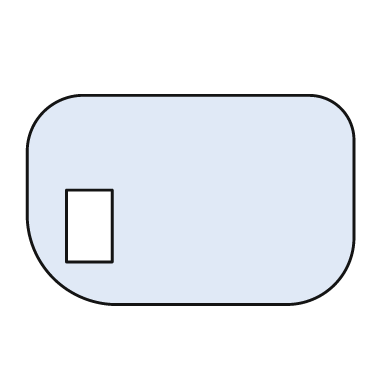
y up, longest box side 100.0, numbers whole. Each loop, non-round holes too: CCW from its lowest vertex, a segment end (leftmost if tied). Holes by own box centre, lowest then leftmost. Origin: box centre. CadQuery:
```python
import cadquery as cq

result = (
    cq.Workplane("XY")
    .moveTo(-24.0, -32.0)
    .lineTo(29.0, -32.0)
    .threePointArc((44.0, -26.0), (50.0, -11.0))
    .lineTo(50.0, 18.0)
    .threePointArc((46.0, 28.0), (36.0, 32.0))
    .lineTo(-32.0, 32.0)
    .threePointArc((-45.0, 27.0), (-50.0, 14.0))
    .lineTo(-50.0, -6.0)
    .threePointArc((-42.0, -24.0), (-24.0, -32.0))
    .close()
    .moveTo(-38.0, -19.0)
    .lineTo(-24.0, -19.0)
    .lineTo(-24.0, 3.0)
    .lineTo(-38.0, 3.0)
    .close()
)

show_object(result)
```